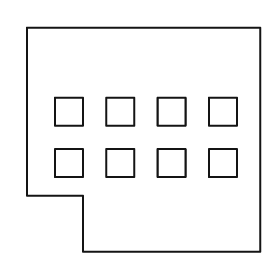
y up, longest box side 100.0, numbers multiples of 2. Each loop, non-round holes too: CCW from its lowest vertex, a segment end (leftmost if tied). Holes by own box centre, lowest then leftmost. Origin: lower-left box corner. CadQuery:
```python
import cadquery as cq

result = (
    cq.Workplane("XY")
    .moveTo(24.0, 0.0)
    .lineTo(100.0, 0.0)
    .lineTo(100.0, 96.0)
    .lineTo(0.0, 96.0)
    .lineTo(0.0, 24.0)
    .lineTo(24.0, 24.0)
    .close()
    .moveTo(12.0, 32.0)
    .lineTo(24.0, 32.0)
    .lineTo(24.0, 44.0)
    .lineTo(12.0, 44.0)
    .close()
    .moveTo(34.0, 32.0)
    .lineTo(46.0, 32.0)
    .lineTo(46.0, 44.0)
    .lineTo(34.0, 44.0)
    .close()
    .moveTo(56.0, 32.0)
    .lineTo(68.0, 32.0)
    .lineTo(68.0, 44.0)
    .lineTo(56.0, 44.0)
    .close()
    .moveTo(78.0, 32.0)
    .lineTo(90.0, 32.0)
    .lineTo(90.0, 44.0)
    .lineTo(78.0, 44.0)
    .close()
    .moveTo(12.0, 54.0)
    .lineTo(24.0, 54.0)
    .lineTo(24.0, 66.0)
    .lineTo(12.0, 66.0)
    .close()
    .moveTo(34.0, 54.0)
    .lineTo(46.0, 54.0)
    .lineTo(46.0, 66.0)
    .lineTo(34.0, 66.0)
    .close()
    .moveTo(56.0, 54.0)
    .lineTo(68.0, 54.0)
    .lineTo(68.0, 66.0)
    .lineTo(56.0, 66.0)
    .close()
    .moveTo(78.0, 54.0)
    .lineTo(90.0, 54.0)
    .lineTo(90.0, 66.0)
    .lineTo(78.0, 66.0)
    .close()
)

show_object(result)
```